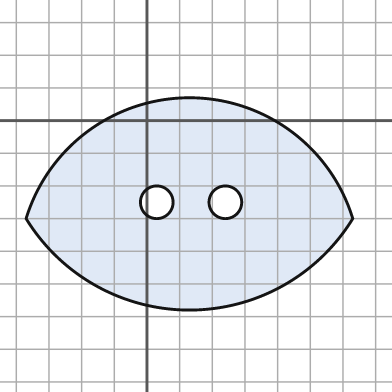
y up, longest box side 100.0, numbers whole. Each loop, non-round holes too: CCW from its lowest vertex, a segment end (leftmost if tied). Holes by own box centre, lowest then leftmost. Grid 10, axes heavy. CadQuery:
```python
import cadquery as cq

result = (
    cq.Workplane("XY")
    .moveTo(-37.0, -30.0)
    .threePointArc((13.0, -58.0), (63.0, -30.0))
    .threePointArc((13.0, 7.0), (-37.0, -30.0))
    .close()
    .moveTo(3.0, -25.0)
    .circle(5.0)
    .moveTo(24.0, -25.0)
    .circle(5.0)
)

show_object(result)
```